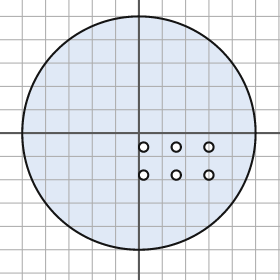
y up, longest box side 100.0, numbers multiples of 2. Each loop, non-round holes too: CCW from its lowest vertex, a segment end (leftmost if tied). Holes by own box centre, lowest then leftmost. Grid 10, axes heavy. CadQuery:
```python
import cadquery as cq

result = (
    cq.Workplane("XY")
    .moveTo(0.0, 0.0)
    .circle(50.0)
    .moveTo(2.0, -18.0)
    .circle(2.0)
    .moveTo(16.0, -18.0)
    .circle(2.0)
    .moveTo(30.0, -18.0)
    .circle(2.0)
    .moveTo(2.0, -6.0)
    .circle(2.0)
    .moveTo(16.0, -6.0)
    .circle(2.0)
    .moveTo(30.0, -6.0)
    .circle(2.0)
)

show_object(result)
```